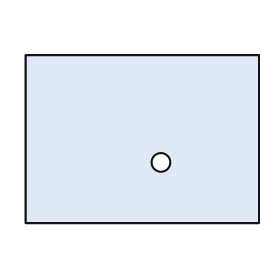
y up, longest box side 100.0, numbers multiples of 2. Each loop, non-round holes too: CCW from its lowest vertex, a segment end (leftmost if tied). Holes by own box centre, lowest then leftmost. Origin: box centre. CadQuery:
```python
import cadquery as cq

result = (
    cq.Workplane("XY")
    .moveTo(-50.0, -36.0)
    .lineTo(50.0, -36.0)
    .lineTo(50.0, 36.0)
    .lineTo(-50.0, 36.0)
    .close()
    .moveTo(8.0, -10.0)
    .circle(4.0)
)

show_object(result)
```